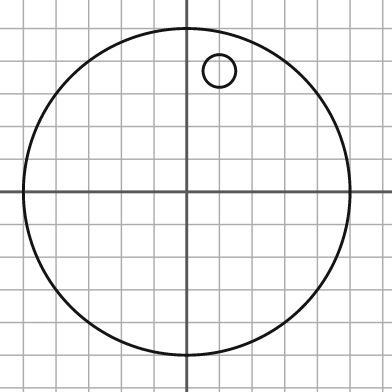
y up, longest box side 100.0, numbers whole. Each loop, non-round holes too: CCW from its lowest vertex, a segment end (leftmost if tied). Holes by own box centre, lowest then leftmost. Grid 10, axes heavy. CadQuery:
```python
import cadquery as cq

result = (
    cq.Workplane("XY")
    .moveTo(0.0, 0.0)
    .circle(50.0)
    .moveTo(10.0, 37.0)
    .circle(5.0)
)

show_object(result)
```